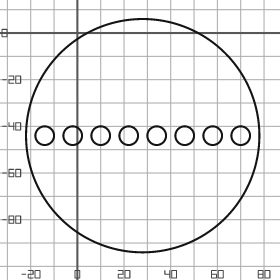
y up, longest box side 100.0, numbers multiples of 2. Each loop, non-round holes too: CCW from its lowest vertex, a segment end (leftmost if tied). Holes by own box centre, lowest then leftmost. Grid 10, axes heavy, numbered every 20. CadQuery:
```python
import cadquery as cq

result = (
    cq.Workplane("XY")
    .moveTo(28.0, -44.0)
    .circle(50.0)
    .moveTo(-14.0, -44.0)
    .circle(4.0)
    .moveTo(-2.0, -44.0)
    .circle(4.0)
    .moveTo(10.0, -44.0)
    .circle(4.0)
    .moveTo(22.0, -44.0)
    .circle(4.0)
    .moveTo(34.0, -44.0)
    .circle(4.0)
    .moveTo(46.0, -44.0)
    .circle(4.0)
    .moveTo(58.0, -44.0)
    .circle(4.0)
    .moveTo(70.0, -44.0)
    .circle(4.0)
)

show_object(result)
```